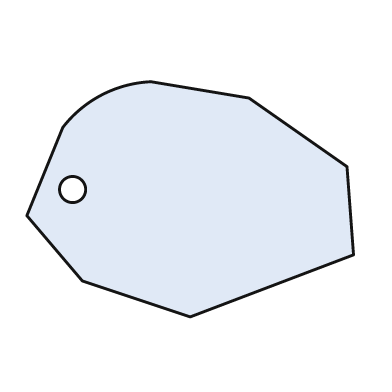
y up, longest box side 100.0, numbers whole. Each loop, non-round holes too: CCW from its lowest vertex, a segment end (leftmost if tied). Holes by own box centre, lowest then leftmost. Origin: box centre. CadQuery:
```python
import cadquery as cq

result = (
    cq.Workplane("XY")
    .moveTo(0.0, -36.0)
    .lineTo(50.0, -17.0)
    .lineTo(48.0, 10.0)
    .lineTo(18.0, 31.0)
    .lineTo(-12.0, 36.0)
    .threePointArc((-27.0, 32.0), (-39.0, 22.0))
    .lineTo(-50.0, -5.0)
    .lineTo(-33.0, -25.0)
    .close()
    .moveTo(-36.0, 3.0)
    .circle(4.0)
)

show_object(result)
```